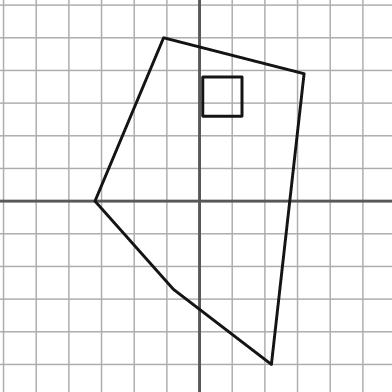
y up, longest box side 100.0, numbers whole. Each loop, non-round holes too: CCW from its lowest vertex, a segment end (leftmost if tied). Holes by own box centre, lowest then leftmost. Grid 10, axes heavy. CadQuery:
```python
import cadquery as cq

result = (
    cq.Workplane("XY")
    .moveTo(22.0, -50.0)
    .lineTo(32.0, 39.0)
    .lineTo(-11.0, 50.0)
    .lineTo(-32.0, 0.0)
    .lineTo(-8.0, -27.0)
    .close()
    .moveTo(1.0, 26.0)
    .lineTo(13.0, 26.0)
    .lineTo(13.0, 38.0)
    .lineTo(1.0, 38.0)
    .close()
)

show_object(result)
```